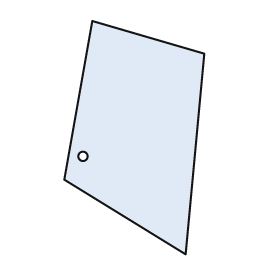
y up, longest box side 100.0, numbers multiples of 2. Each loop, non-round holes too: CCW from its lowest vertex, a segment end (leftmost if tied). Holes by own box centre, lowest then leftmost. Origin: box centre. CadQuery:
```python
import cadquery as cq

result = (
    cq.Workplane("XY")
    .moveTo(22.0, -50.0)
    .lineTo(30.0, 36.0)
    .lineTo(-18.0, 50.0)
    .lineTo(-30.0, -18.0)
    .close()
    .moveTo(-22.0, -8.0)
    .circle(2.0)
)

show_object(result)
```